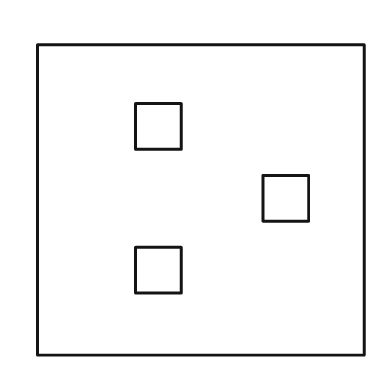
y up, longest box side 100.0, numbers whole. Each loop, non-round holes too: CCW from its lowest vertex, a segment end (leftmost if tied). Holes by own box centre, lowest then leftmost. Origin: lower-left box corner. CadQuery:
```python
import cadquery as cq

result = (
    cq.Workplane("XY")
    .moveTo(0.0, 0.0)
    .lineTo(100.0, 0.0)
    .lineTo(100.0, 95.0)
    .lineTo(0.0, 95.0)
    .close()
    .moveTo(30.0, 19.0)
    .lineTo(44.0, 19.0)
    .lineTo(44.0, 33.0)
    .lineTo(30.0, 33.0)
    .close()
    .moveTo(69.0, 41.0)
    .lineTo(83.0, 41.0)
    .lineTo(83.0, 55.0)
    .lineTo(69.0, 55.0)
    .close()
    .moveTo(30.0, 63.0)
    .lineTo(44.0, 63.0)
    .lineTo(44.0, 77.0)
    .lineTo(30.0, 77.0)
    .close()
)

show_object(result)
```